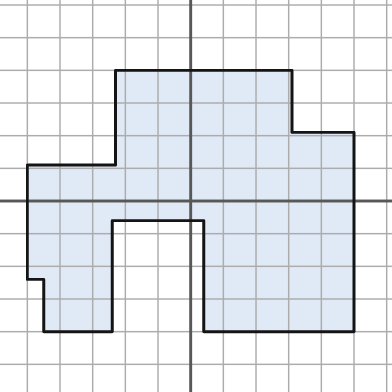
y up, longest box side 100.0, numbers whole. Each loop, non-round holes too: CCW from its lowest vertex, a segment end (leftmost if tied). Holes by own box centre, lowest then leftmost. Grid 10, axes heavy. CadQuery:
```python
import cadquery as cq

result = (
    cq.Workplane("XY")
    .moveTo(-45.0, -40.0)
    .lineTo(-24.0, -40.0)
    .lineTo(-24.0, -6.0)
    .lineTo(4.0, -6.0)
    .lineTo(4.0, -40.0)
    .lineTo(50.0, -40.0)
    .lineTo(50.0, 21.0)
    .lineTo(31.0, 21.0)
    .lineTo(31.0, 40.0)
    .lineTo(-23.0, 40.0)
    .lineTo(-23.0, 11.0)
    .lineTo(-50.0, 11.0)
    .lineTo(-50.0, -24.0)
    .lineTo(-45.0, -24.0)
    .close()
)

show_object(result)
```